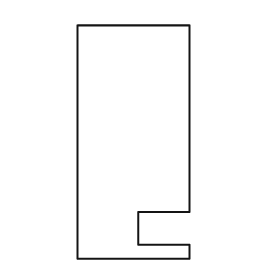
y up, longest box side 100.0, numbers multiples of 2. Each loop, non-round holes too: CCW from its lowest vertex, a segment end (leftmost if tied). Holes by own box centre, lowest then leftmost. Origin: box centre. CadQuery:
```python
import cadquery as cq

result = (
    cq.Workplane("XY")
    .moveTo(-24.0, -50.0)
    .lineTo(24.0, -50.0)
    .lineTo(24.0, -44.0)
    .lineTo(2.0, -44.0)
    .lineTo(2.0, -30.0)
    .lineTo(24.0, -30.0)
    .lineTo(24.0, 50.0)
    .lineTo(-24.0, 50.0)
    .close()
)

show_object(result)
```